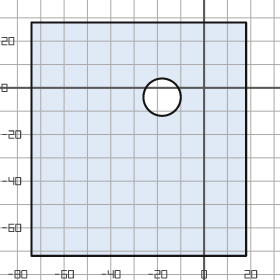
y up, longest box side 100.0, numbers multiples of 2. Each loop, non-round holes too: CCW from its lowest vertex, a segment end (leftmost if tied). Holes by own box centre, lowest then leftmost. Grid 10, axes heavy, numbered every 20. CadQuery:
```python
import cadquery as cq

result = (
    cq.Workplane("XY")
    .moveTo(-74.0, -72.0)
    .lineTo(18.0, -72.0)
    .lineTo(18.0, 28.0)
    .lineTo(-74.0, 28.0)
    .close()
    .moveTo(-18.0, -4.0)
    .circle(8.0)
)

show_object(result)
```